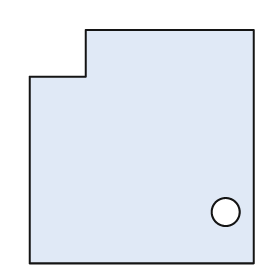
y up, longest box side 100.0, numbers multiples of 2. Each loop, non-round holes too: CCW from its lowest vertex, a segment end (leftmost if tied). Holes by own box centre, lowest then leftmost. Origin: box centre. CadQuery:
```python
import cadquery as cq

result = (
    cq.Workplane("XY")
    .moveTo(-48.0, -50.0)
    .lineTo(48.0, -50.0)
    .lineTo(48.0, 50.0)
    .lineTo(-24.0, 50.0)
    .lineTo(-24.0, 30.0)
    .lineTo(-48.0, 30.0)
    .close()
    .moveTo(36.0, -28.0)
    .circle(6.0)
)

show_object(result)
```